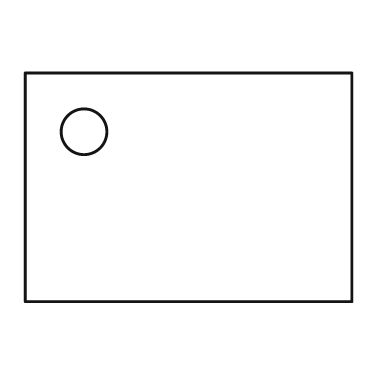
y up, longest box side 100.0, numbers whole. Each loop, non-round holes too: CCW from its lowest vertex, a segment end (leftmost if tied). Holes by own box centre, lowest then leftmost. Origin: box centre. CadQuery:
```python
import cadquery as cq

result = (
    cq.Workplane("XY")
    .moveTo(-50.0, -35.0)
    .lineTo(50.0, -35.0)
    .lineTo(50.0, 35.0)
    .lineTo(-50.0, 35.0)
    .close()
    .moveTo(-32.0, 17.0)
    .circle(7.0)
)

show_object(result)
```